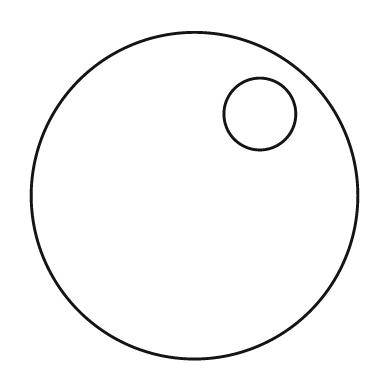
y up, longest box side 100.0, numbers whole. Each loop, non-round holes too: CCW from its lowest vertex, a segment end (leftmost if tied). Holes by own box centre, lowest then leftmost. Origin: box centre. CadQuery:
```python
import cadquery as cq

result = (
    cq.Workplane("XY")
    .moveTo(0.0, 0.0)
    .circle(50.0)
    .moveTo(20.0, 25.0)
    .circle(11.0)
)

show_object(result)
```